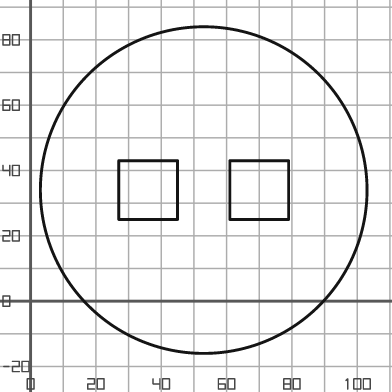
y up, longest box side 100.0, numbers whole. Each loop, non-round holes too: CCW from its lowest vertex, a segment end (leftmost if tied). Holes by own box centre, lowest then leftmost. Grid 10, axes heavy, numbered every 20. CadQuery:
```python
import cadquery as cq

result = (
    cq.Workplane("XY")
    .moveTo(53.0, 34.0)
    .circle(50.0)
    .moveTo(27.0, 25.0)
    .lineTo(45.0, 25.0)
    .lineTo(45.0, 43.0)
    .lineTo(27.0, 43.0)
    .close()
    .moveTo(61.0, 25.0)
    .lineTo(79.0, 25.0)
    .lineTo(79.0, 43.0)
    .lineTo(61.0, 43.0)
    .close()
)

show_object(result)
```